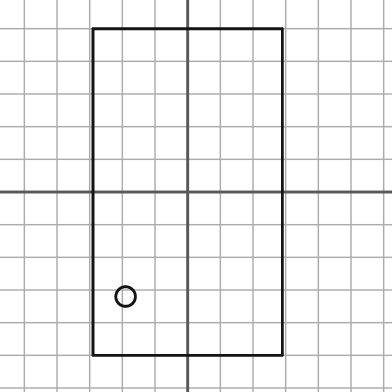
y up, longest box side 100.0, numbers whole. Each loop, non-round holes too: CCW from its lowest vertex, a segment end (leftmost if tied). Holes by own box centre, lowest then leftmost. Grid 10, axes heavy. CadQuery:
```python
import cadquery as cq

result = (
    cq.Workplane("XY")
    .moveTo(-29.0, -50.0)
    .lineTo(29.0, -50.0)
    .lineTo(29.0, 50.0)
    .lineTo(-29.0, 50.0)
    .close()
    .moveTo(-19.0, -32.0)
    .circle(3.0)
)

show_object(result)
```